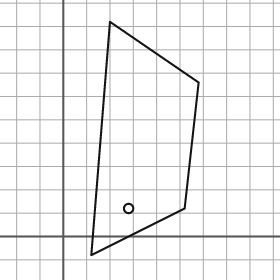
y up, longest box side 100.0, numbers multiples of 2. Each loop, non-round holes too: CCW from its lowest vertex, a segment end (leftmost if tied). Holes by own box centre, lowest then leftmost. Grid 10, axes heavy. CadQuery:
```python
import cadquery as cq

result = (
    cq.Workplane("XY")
    .moveTo(12.0, -8.0)
    .lineTo(52.0, 12.0)
    .lineTo(58.0, 66.0)
    .lineTo(20.0, 92.0)
    .close()
    .moveTo(28.0, 12.0)
    .circle(2.0)
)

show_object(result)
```